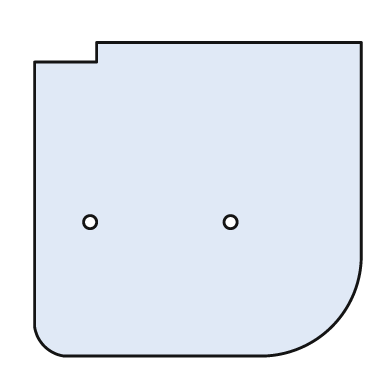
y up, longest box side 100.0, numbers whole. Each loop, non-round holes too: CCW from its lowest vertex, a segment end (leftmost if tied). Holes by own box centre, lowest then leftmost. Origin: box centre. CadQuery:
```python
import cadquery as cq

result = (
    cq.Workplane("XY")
    .moveTo(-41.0, -48.0)
    .lineTo(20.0, -48.0)
    .threePointArc((41.0, -39.0), (50.0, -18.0))
    .lineTo(50.0, 48.0)
    .lineTo(-31.0, 48.0)
    .lineTo(-31.0, 42.0)
    .lineTo(-50.0, 42.0)
    .lineTo(-50.0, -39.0)
    .threePointArc((-47.0, -45.0), (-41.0, -48.0))
    .close()
    .moveTo(-33.0, -7.0)
    .circle(2.0)
    .moveTo(10.0, -7.0)
    .circle(2.0)
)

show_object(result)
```